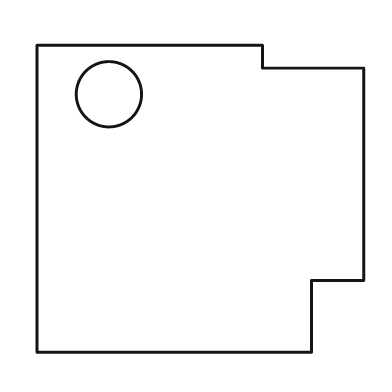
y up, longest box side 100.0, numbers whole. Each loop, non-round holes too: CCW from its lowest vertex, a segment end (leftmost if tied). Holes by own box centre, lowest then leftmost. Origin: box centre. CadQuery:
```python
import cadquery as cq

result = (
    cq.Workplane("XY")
    .moveTo(-50.0, -47.0)
    .lineTo(34.0, -47.0)
    .lineTo(34.0, -25.0)
    .lineTo(50.0, -25.0)
    .lineTo(50.0, 40.0)
    .lineTo(19.0, 40.0)
    .lineTo(19.0, 47.0)
    .lineTo(-50.0, 47.0)
    .close()
    .moveTo(-28.0, 32.0)
    .circle(10.0)
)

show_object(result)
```